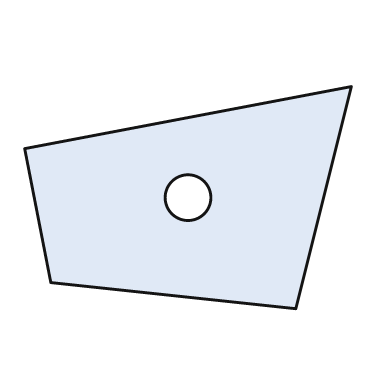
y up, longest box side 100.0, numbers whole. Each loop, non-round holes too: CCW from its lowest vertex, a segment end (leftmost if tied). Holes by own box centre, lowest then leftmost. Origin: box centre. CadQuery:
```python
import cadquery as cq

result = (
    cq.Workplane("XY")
    .moveTo(33.0, -34.0)
    .lineTo(50.0, 34.0)
    .lineTo(-50.0, 15.0)
    .lineTo(-42.0, -26.0)
    .close()
    .moveTo(0.0, 0.0)
    .circle(7.0)
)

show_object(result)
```